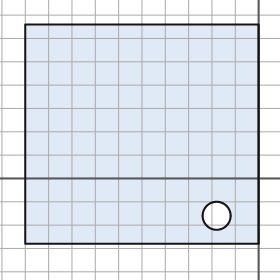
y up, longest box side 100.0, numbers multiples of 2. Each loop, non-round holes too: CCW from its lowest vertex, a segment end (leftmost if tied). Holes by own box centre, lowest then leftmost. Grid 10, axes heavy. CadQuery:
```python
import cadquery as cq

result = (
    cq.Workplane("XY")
    .moveTo(-100.0, -28.0)
    .lineTo(0.0, -28.0)
    .lineTo(0.0, 66.0)
    .lineTo(-100.0, 66.0)
    .close()
    .moveTo(-18.0, -16.0)
    .circle(6.0)
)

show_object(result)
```